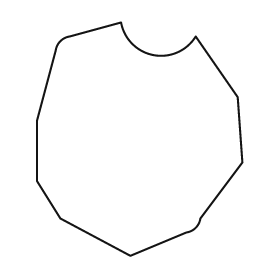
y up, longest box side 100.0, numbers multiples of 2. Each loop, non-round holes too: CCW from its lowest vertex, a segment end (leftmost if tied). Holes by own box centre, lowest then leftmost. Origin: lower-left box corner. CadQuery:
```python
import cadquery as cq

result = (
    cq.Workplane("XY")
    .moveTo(40.0, 0.0)
    .lineTo(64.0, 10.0)
    .threePointArc((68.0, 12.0), (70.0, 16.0))
    .lineTo(88.0, 40.0)
    .lineTo(86.0, 68.0)
    .lineTo(68.0, 94.0)
    .threePointArc((50.0, 86.0), (36.0, 100.0))
    .lineTo(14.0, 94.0)
    .threePointArc((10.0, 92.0), (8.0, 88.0))
    .lineTo(0.0, 58.0)
    .lineTo(0.0, 32.0)
    .lineTo(10.0, 16.0)
    .close()
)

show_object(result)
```